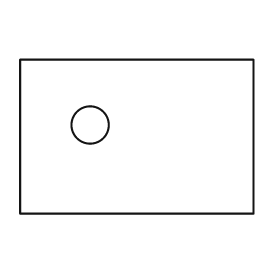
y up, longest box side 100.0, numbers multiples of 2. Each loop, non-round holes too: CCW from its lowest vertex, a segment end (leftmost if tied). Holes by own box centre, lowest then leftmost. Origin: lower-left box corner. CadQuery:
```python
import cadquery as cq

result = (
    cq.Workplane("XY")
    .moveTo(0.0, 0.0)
    .lineTo(100.0, 0.0)
    .lineTo(100.0, 66.0)
    .lineTo(0.0, 66.0)
    .close()
    .moveTo(30.0, 38.0)
    .circle(8.0)
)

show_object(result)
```